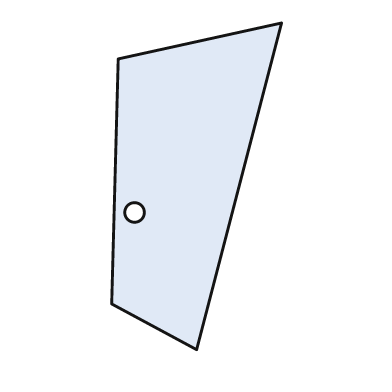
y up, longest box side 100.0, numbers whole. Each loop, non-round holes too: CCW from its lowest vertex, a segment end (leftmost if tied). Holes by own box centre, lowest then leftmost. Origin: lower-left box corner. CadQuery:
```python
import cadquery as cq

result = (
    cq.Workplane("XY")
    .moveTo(26.0, 0.0)
    .lineTo(52.0, 100.0)
    .lineTo(2.0, 89.0)
    .lineTo(0.0, 14.0)
    .close()
    .moveTo(7.0, 42.0)
    .circle(3.0)
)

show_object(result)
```